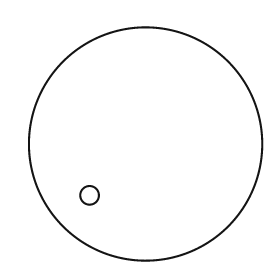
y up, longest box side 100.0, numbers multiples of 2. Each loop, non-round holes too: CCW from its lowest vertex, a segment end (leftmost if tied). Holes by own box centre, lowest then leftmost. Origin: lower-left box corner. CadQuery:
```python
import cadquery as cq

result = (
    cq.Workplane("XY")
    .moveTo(50.0, 50.0)
    .circle(50.0)
    .moveTo(26.0, 28.0)
    .circle(4.0)
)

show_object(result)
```